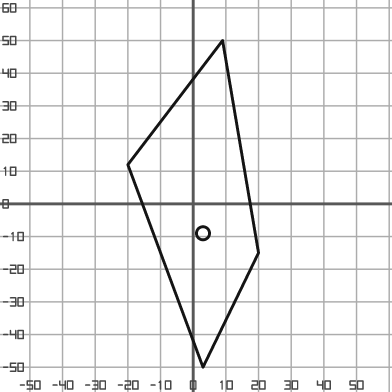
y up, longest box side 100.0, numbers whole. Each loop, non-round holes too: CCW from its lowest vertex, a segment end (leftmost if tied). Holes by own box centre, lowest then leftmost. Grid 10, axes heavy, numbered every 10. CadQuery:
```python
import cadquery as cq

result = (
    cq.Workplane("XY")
    .moveTo(3.0, -50.0)
    .lineTo(20.0, -15.0)
    .lineTo(9.0, 50.0)
    .lineTo(-20.0, 12.0)
    .close()
    .moveTo(3.0, -9.0)
    .circle(2.0)
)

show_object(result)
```